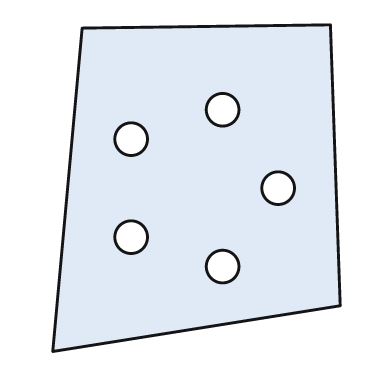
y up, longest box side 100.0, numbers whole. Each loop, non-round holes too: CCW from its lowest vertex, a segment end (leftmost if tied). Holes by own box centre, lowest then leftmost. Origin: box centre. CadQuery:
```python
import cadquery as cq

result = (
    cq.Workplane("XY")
    .moveTo(-44.0, -50.0)
    .lineTo(44.0, -36.0)
    .lineTo(41.0, 50.0)
    .lineTo(-35.0, 49.0)
    .close()
    .moveTo(8.0, -24.0)
    .circle(5.0)
    .moveTo(-20.0, -15.0)
    .circle(5.0)
    .moveTo(25.0, 0.0)
    .circle(5.0)
    .moveTo(-20.0, 15.0)
    .circle(5.0)
    .moveTo(8.0, 24.0)
    .circle(5.0)
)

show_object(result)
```